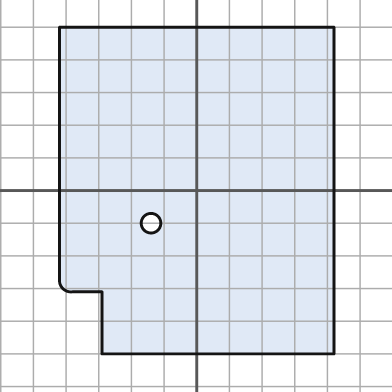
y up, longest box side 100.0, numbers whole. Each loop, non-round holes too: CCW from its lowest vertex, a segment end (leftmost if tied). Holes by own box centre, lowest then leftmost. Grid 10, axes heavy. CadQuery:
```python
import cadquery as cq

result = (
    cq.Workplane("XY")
    .moveTo(-29.0, -50.0)
    .lineTo(42.0, -50.0)
    .lineTo(42.0, 50.0)
    .lineTo(-42.0, 50.0)
    .lineTo(-42.0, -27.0)
    .threePointArc((-41.0, -30.0), (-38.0, -31.0))
    .lineTo(-29.0, -31.0)
    .close()
    .moveTo(-14.0, -10.0)
    .circle(3.0)
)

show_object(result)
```